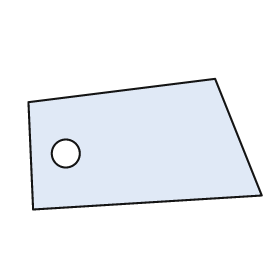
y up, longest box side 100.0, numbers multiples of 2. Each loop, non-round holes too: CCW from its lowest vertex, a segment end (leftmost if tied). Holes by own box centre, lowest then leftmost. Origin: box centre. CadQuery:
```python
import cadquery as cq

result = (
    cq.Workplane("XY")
    .moveTo(-48.0, -28.0)
    .lineTo(50.0, -22.0)
    .lineTo(30.0, 28.0)
    .lineTo(-50.0, 18.0)
    .close()
    .moveTo(-34.0, -4.0)
    .circle(6.0)
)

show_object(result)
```